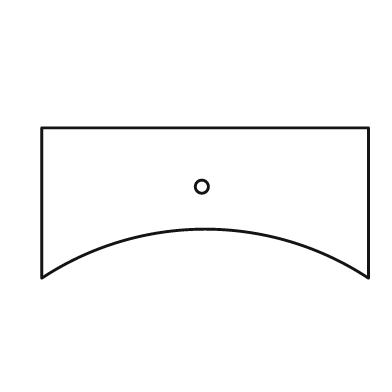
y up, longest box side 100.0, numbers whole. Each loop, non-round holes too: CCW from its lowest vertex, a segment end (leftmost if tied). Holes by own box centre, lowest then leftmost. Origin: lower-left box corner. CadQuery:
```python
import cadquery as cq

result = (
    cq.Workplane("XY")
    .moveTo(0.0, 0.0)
    .threePointArc((50.0, 15.0), (100.0, 0.0))
    .lineTo(100.0, 46.0)
    .lineTo(0.0, 46.0)
    .close()
    .moveTo(49.0, 28.0)
    .circle(2.0)
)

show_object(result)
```